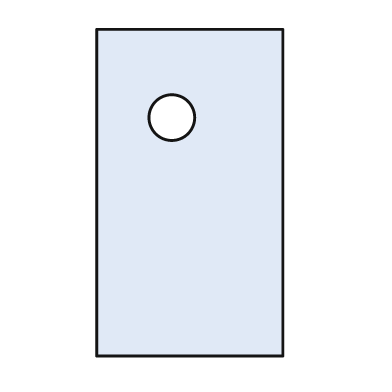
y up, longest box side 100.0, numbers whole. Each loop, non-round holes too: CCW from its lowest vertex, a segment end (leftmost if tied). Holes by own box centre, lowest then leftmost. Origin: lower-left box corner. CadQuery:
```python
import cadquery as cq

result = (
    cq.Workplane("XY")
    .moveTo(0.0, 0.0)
    .lineTo(57.0, 0.0)
    .lineTo(57.0, 100.0)
    .lineTo(0.0, 100.0)
    .close()
    .moveTo(23.0, 73.0)
    .circle(7.0)
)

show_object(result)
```